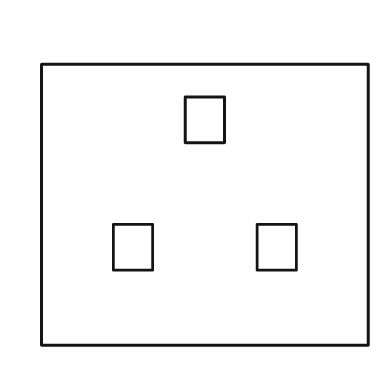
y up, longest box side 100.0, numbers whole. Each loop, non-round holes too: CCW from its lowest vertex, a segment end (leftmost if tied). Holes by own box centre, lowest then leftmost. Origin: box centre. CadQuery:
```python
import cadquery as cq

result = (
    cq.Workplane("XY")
    .moveTo(-50.0, -43.0)
    .lineTo(50.0, -43.0)
    .lineTo(50.0, 43.0)
    .lineTo(-50.0, 43.0)
    .close()
    .moveTo(-28.0, -20.0)
    .lineTo(-16.0, -20.0)
    .lineTo(-16.0, -6.0)
    .lineTo(-28.0, -6.0)
    .close()
    .moveTo(16.0, -20.0)
    .lineTo(28.0, -20.0)
    .lineTo(28.0, -6.0)
    .lineTo(16.0, -6.0)
    .close()
    .moveTo(-6.0, 19.0)
    .lineTo(6.0, 19.0)
    .lineTo(6.0, 33.0)
    .lineTo(-6.0, 33.0)
    .close()
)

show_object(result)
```